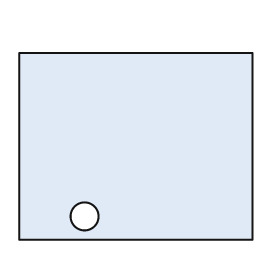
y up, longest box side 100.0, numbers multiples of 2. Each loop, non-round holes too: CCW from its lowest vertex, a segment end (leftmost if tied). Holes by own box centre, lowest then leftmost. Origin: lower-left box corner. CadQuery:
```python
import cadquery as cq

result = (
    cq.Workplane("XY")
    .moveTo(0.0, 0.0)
    .lineTo(100.0, 0.0)
    .lineTo(100.0, 80.0)
    .lineTo(0.0, 80.0)
    .close()
    .moveTo(28.0, 10.0)
    .circle(6.0)
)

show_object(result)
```